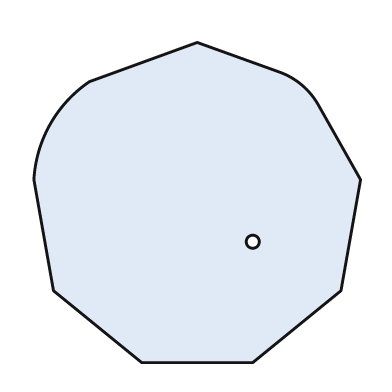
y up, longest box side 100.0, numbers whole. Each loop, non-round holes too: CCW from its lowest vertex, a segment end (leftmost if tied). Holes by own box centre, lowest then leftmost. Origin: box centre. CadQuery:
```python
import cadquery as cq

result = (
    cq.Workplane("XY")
    .moveTo(-17.0, -49.0)
    .lineTo(17.0, -49.0)
    .lineTo(44.0, -27.0)
    .lineTo(50.0, 7.0)
    .lineTo(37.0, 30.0)
    .threePointArc((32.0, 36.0), (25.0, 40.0))
    .lineTo(0.0, 49.0)
    .lineTo(-33.0, 37.0)
    .threePointArc((-45.0, 24.0), (-50.0, 7.0))
    .lineTo(-44.0, -27.0)
    .close()
    .moveTo(17.0, -12.0)
    .circle(2.0)
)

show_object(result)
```